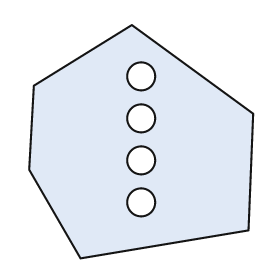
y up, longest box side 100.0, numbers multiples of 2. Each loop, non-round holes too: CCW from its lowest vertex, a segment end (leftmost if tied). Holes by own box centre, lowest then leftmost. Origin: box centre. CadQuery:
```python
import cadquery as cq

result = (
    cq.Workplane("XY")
    .moveTo(-26.0, -50.0)
    .lineTo(46.0, -38.0)
    .lineTo(48.0, 12.0)
    .lineTo(-4.0, 50.0)
    .lineTo(-46.0, 24.0)
    .lineTo(-48.0, -12.0)
    .close()
    .moveTo(0.0, -26.0)
    .circle(6.0)
    .moveTo(0.0, -8.0)
    .circle(6.0)
    .moveTo(0.0, 10.0)
    .circle(6.0)
    .moveTo(0.0, 28.0)
    .circle(6.0)
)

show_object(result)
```